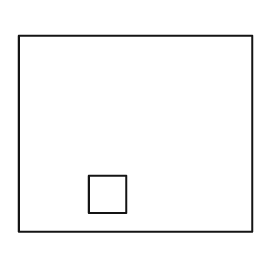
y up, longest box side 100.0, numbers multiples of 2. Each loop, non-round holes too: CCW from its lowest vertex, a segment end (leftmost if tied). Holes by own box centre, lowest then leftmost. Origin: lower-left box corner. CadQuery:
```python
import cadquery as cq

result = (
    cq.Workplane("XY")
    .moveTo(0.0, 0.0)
    .lineTo(100.0, 0.0)
    .lineTo(100.0, 84.0)
    .lineTo(0.0, 84.0)
    .close()
    .moveTo(30.0, 8.0)
    .lineTo(46.0, 8.0)
    .lineTo(46.0, 24.0)
    .lineTo(30.0, 24.0)
    .close()
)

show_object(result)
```